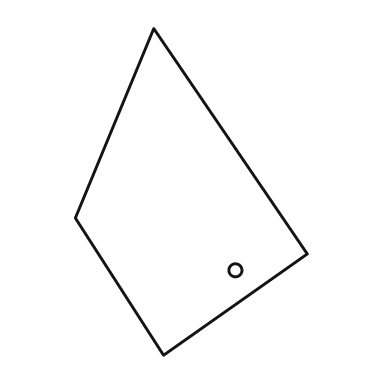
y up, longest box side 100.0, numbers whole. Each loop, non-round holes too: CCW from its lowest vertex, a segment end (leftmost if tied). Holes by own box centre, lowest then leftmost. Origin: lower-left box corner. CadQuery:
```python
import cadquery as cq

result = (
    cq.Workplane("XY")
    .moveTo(27.0, 0.0)
    .lineTo(71.0, 31.0)
    .lineTo(24.0, 100.0)
    .lineTo(0.0, 42.0)
    .close()
    .moveTo(49.0, 26.0)
    .circle(2.0)
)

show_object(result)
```